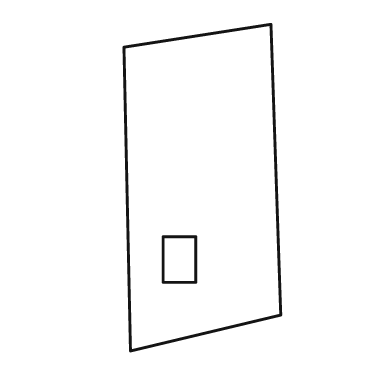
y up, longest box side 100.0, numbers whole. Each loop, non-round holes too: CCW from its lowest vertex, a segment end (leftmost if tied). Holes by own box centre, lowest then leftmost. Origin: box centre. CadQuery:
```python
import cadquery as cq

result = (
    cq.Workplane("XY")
    .moveTo(-22.0, -50.0)
    .lineTo(24.0, -39.0)
    .lineTo(21.0, 50.0)
    .lineTo(-24.0, 43.0)
    .close()
    .moveTo(-12.0, -29.0)
    .lineTo(-2.0, -29.0)
    .lineTo(-2.0, -15.0)
    .lineTo(-12.0, -15.0)
    .close()
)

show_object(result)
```